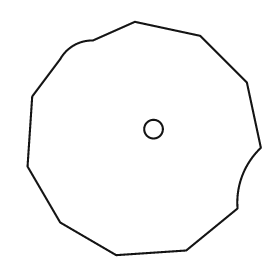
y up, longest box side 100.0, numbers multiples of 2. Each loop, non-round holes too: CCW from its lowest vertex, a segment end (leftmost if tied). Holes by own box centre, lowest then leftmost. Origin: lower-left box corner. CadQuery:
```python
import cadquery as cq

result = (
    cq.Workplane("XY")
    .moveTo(38.0, 0.0)
    .lineTo(68.0, 2.0)
    .lineTo(90.0, 20.0)
    .threePointArc((92.0, 34.0), (100.0, 46.0))
    .lineTo(94.0, 74.0)
    .lineTo(74.0, 94.0)
    .lineTo(46.0, 100.0)
    .lineTo(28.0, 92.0)
    .threePointArc((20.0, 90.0), (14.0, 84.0))
    .lineTo(2.0, 68.0)
    .lineTo(0.0, 38.0)
    .lineTo(14.0, 14.0)
    .close()
    .moveTo(54.0, 54.0)
    .circle(4.0)
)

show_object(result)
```